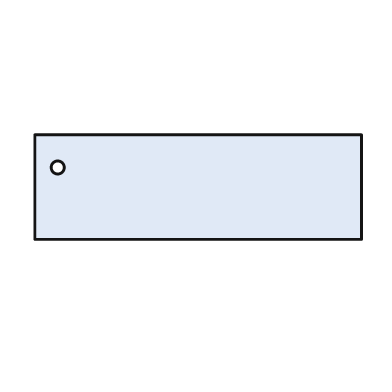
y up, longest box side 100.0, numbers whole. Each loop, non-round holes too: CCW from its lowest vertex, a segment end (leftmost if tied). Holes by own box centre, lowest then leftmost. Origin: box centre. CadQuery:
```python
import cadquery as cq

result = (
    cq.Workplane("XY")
    .moveTo(-50.0, -16.0)
    .lineTo(50.0, -16.0)
    .lineTo(50.0, 16.0)
    .lineTo(-50.0, 16.0)
    .close()
    .moveTo(-43.0, 6.0)
    .circle(2.0)
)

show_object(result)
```